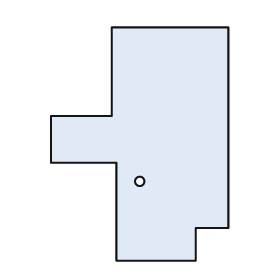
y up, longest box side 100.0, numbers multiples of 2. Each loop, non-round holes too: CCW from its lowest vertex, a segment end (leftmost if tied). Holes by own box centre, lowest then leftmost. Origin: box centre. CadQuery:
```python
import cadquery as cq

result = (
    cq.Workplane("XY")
    .moveTo(-10.0, -50.0)
    .lineTo(24.0, -50.0)
    .lineTo(24.0, -36.0)
    .lineTo(38.0, -36.0)
    .lineTo(38.0, 50.0)
    .lineTo(-12.0, 50.0)
    .lineTo(-12.0, 12.0)
    .lineTo(-38.0, 12.0)
    .lineTo(-38.0, -8.0)
    .lineTo(-10.0, -8.0)
    .close()
    .moveTo(0.0, -16.0)
    .circle(2.0)
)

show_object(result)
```